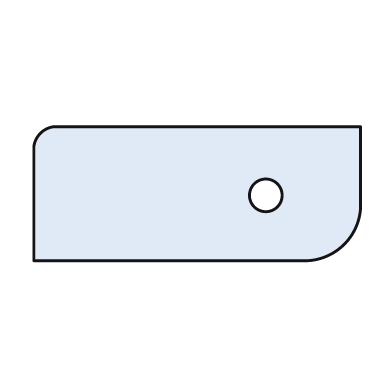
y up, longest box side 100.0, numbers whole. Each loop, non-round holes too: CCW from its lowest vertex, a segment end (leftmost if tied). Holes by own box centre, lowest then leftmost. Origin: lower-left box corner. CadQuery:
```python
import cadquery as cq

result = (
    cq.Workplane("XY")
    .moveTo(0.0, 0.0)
    .lineTo(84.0, 0.0)
    .threePointArc((95.0, 5.0), (100.0, 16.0))
    .lineTo(100.0, 41.0)
    .lineTo(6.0, 41.0)
    .threePointArc((2.0, 39.0), (0.0, 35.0))
    .close()
    .moveTo(71.0, 20.0)
    .circle(5.0)
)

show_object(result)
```